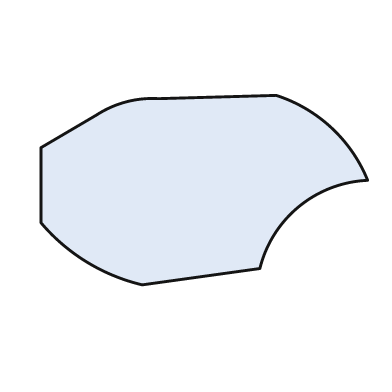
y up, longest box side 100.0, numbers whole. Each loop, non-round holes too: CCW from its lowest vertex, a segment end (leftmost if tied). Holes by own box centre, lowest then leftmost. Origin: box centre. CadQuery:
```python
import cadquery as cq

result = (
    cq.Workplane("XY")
    .moveTo(-19.0, -29.0)
    .lineTo(17.0, -24.0)
    .threePointArc((29.0, -5.0), (50.0, 3.0))
    .threePointArc((39.0, 19.0), (22.0, 29.0))
    .lineTo(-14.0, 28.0)
    .threePointArc((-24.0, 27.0), (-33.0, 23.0))
    .lineTo(-50.0, 13.0)
    .lineTo(-50.0, -10.0)
    .threePointArc((-36.0, -22.0), (-19.0, -29.0))
    .close()
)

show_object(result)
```